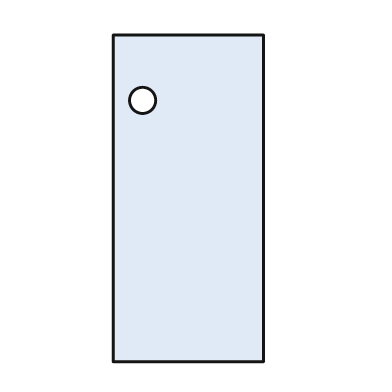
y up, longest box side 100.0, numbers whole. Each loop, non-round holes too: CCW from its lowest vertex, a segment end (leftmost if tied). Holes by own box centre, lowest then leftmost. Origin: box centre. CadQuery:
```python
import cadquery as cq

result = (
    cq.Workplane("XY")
    .moveTo(-23.0, -50.0)
    .lineTo(23.0, -50.0)
    .lineTo(23.0, 50.0)
    .lineTo(-23.0, 50.0)
    .close()
    .moveTo(-14.0, 30.0)
    .circle(4.0)
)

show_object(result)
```